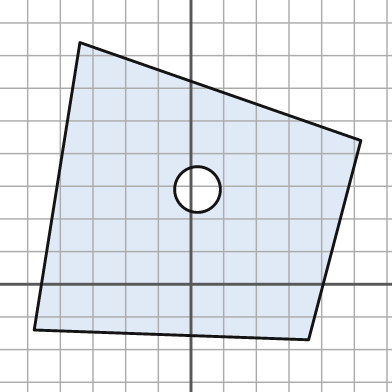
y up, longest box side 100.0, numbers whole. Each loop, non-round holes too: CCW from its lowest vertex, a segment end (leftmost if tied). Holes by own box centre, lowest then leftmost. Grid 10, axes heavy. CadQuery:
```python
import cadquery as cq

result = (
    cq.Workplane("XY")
    .moveTo(36.0, -17.0)
    .lineTo(52.0, 44.0)
    .lineTo(-34.0, 74.0)
    .lineTo(-48.0, -14.0)
    .close()
    .moveTo(2.0, 29.0)
    .circle(7.0)
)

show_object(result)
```